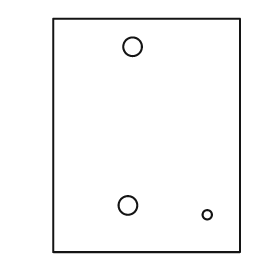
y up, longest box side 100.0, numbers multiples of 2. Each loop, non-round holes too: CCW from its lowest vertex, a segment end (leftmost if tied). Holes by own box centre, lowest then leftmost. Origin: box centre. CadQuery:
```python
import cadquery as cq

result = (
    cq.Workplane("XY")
    .moveTo(-40.0, -50.0)
    .lineTo(40.0, -50.0)
    .lineTo(40.0, 50.0)
    .lineTo(-40.0, 50.0)
    .close()
    .moveTo(26.0, -34.0)
    .circle(2.0)
    .moveTo(-8.0, -30.0)
    .circle(4.0)
    .moveTo(-6.0, 38.0)
    .circle(4.0)
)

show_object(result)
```